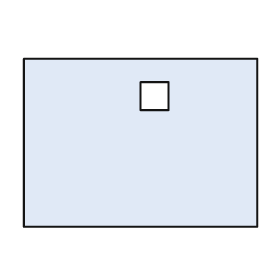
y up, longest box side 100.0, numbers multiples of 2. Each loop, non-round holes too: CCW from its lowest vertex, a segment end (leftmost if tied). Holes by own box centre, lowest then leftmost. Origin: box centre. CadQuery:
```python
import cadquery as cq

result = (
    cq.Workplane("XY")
    .moveTo(-50.0, -36.0)
    .lineTo(50.0, -36.0)
    .lineTo(50.0, 36.0)
    .lineTo(-50.0, 36.0)
    .close()
    .moveTo(0.0, 14.0)
    .lineTo(12.0, 14.0)
    .lineTo(12.0, 26.0)
    .lineTo(0.0, 26.0)
    .close()
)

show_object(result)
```